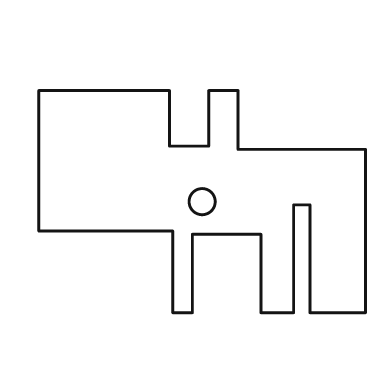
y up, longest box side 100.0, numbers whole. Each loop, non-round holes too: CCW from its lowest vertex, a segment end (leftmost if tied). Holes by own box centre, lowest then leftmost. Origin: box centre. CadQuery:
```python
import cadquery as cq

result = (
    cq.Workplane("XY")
    .moveTo(-9.0, -34.0)
    .lineTo(-3.0, -34.0)
    .lineTo(-3.0, -10.0)
    .lineTo(18.0, -10.0)
    .lineTo(18.0, -34.0)
    .lineTo(28.0, -34.0)
    .lineTo(28.0, -1.0)
    .lineTo(33.0, -1.0)
    .lineTo(33.0, -34.0)
    .lineTo(50.0, -34.0)
    .lineTo(50.0, 16.0)
    .lineTo(11.0, 16.0)
    .lineTo(11.0, 34.0)
    .lineTo(2.0, 34.0)
    .lineTo(2.0, 17.0)
    .lineTo(-10.0, 17.0)
    .lineTo(-10.0, 34.0)
    .lineTo(-50.0, 34.0)
    .lineTo(-50.0, -9.0)
    .lineTo(-9.0, -9.0)
    .close()
    .moveTo(0.0, 0.0)
    .circle(4.0)
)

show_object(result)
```